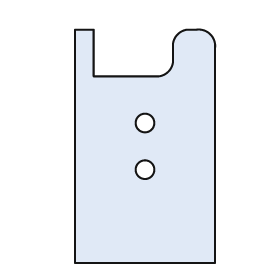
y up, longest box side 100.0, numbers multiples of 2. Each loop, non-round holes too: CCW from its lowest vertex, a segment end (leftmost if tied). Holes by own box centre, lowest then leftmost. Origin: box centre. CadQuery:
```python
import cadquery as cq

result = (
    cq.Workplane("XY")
    .moveTo(-30.0, -50.0)
    .lineTo(30.0, -50.0)
    .lineTo(30.0, 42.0)
    .threePointArc((28.0, 48.0), (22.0, 50.0))
    .lineTo(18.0, 50.0)
    .threePointArc((14.0, 48.0), (12.0, 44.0))
    .lineTo(12.0, 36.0)
    .threePointArc((10.0, 32.0), (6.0, 30.0))
    .lineTo(-22.0, 30.0)
    .lineTo(-22.0, 50.0)
    .lineTo(-30.0, 50.0)
    .close()
    .moveTo(0.0, -10.0)
    .circle(4.0)
    .moveTo(0.0, 10.0)
    .circle(4.0)
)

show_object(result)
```